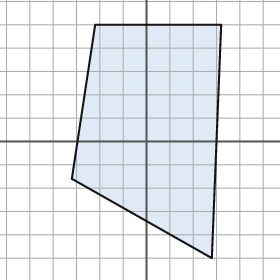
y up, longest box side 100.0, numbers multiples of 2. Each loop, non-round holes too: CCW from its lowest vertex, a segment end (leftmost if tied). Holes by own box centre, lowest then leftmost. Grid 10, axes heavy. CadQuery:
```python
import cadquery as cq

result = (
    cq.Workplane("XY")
    .moveTo(28.0, -50.0)
    .lineTo(32.0, 50.0)
    .lineTo(-22.0, 50.0)
    .lineTo(-32.0, -16.0)
    .close()
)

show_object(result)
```